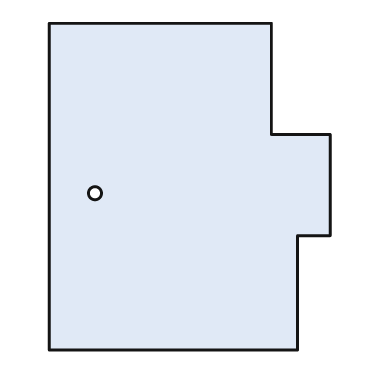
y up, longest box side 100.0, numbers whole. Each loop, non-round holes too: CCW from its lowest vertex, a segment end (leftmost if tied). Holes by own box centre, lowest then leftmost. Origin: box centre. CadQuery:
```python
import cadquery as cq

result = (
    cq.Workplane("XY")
    .moveTo(-43.0, -50.0)
    .lineTo(33.0, -50.0)
    .lineTo(33.0, -15.0)
    .lineTo(43.0, -15.0)
    .lineTo(43.0, 16.0)
    .lineTo(25.0, 16.0)
    .lineTo(25.0, 50.0)
    .lineTo(-43.0, 50.0)
    .close()
    .moveTo(-29.0, -2.0)
    .circle(2.0)
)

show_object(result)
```